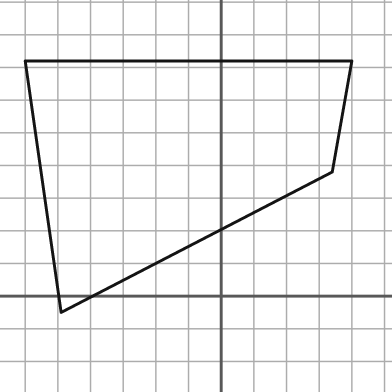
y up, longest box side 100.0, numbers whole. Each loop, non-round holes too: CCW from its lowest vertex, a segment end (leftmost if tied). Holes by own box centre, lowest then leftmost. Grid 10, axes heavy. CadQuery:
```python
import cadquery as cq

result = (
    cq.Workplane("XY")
    .moveTo(-49.0, -5.0)
    .lineTo(34.0, 38.0)
    .lineTo(40.0, 72.0)
    .lineTo(-60.0, 72.0)
    .close()
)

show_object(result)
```